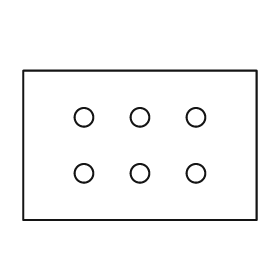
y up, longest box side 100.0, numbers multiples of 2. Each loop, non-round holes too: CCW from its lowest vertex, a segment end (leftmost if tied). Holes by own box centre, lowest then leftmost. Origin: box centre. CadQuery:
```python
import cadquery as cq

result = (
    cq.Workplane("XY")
    .moveTo(-50.0, -32.0)
    .lineTo(50.0, -32.0)
    .lineTo(50.0, 32.0)
    .lineTo(-50.0, 32.0)
    .close()
    .moveTo(-24.0, -12.0)
    .circle(4.0)
    .moveTo(0.0, -12.0)
    .circle(4.0)
    .moveTo(24.0, -12.0)
    .circle(4.0)
    .moveTo(-24.0, 12.0)
    .circle(4.0)
    .moveTo(0.0, 12.0)
    .circle(4.0)
    .moveTo(24.0, 12.0)
    .circle(4.0)
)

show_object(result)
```